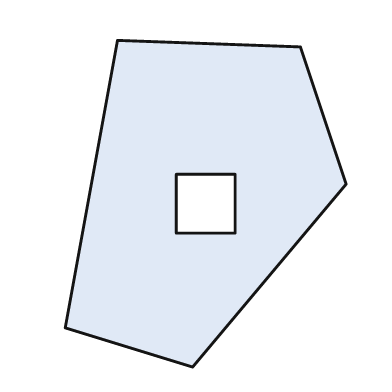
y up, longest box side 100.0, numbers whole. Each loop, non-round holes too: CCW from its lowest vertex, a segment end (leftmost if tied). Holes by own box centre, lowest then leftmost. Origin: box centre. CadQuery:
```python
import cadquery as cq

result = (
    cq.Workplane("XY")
    .moveTo(-4.0, -50.0)
    .lineTo(43.0, 6.0)
    .lineTo(29.0, 48.0)
    .lineTo(-27.0, 50.0)
    .lineTo(-43.0, -38.0)
    .close()
    .moveTo(-9.0, -9.0)
    .lineTo(9.0, -9.0)
    .lineTo(9.0, 9.0)
    .lineTo(-9.0, 9.0)
    .close()
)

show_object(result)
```